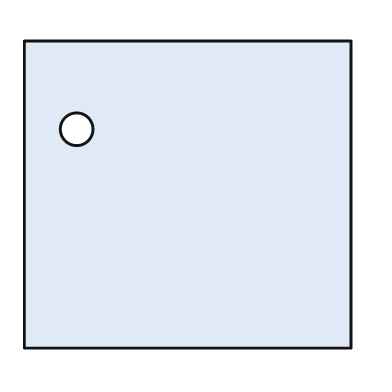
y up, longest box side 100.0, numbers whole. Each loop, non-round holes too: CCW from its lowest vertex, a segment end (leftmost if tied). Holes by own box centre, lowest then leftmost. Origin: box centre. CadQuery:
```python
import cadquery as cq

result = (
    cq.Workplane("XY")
    .moveTo(-50.0, -47.0)
    .lineTo(50.0, -47.0)
    .lineTo(50.0, 47.0)
    .lineTo(-50.0, 47.0)
    .close()
    .moveTo(-34.0, 20.0)
    .circle(5.0)
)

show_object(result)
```